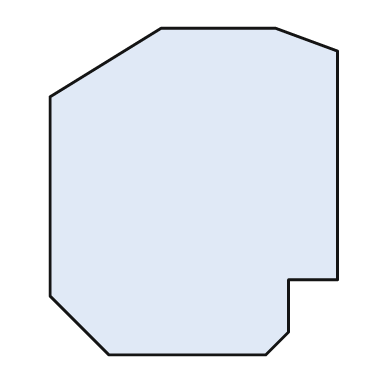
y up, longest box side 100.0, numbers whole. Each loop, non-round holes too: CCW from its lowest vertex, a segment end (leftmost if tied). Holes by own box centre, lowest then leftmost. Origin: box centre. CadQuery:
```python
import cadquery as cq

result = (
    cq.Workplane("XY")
    .moveTo(-26.0, -50.0)
    .lineTo(22.0, -50.0)
    .lineTo(29.0, -43.0)
    .lineTo(29.0, -27.0)
    .lineTo(44.0, -27.0)
    .lineTo(44.0, 43.0)
    .lineTo(25.0, 50.0)
    .lineTo(-10.0, 50.0)
    .lineTo(-44.0, 29.0)
    .lineTo(-44.0, -32.0)
    .close()
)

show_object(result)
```